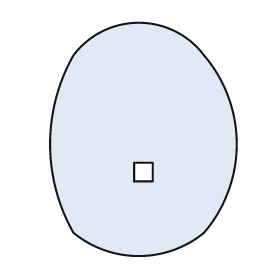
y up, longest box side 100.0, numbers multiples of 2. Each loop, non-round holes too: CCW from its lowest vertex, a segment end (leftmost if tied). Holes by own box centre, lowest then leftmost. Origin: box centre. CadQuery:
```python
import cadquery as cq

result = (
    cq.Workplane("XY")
    .moveTo(-30.0, -40.0)
    .threePointArc((-2.0, -50.0), (26.0, -40.0))
    .threePointArc((40.0, -2.0), (26.0, 36.0))
    .threePointArc((-2.0, 50.0), (-30.0, 36.0))
    .threePointArc((-40.0, -2.0), (-30.0, -40.0))
    .close()
    .moveTo(-4.0, -18.0)
    .lineTo(4.0, -18.0)
    .lineTo(4.0, -10.0)
    .lineTo(-4.0, -10.0)
    .close()
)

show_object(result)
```